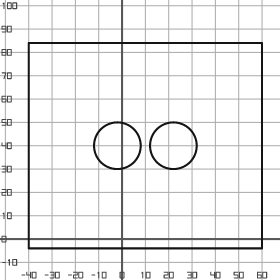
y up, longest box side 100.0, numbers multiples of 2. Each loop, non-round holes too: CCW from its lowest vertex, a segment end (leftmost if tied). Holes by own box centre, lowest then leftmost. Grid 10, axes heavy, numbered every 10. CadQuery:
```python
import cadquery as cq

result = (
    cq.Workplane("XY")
    .moveTo(-40.0, -4.0)
    .lineTo(60.0, -4.0)
    .lineTo(60.0, 84.0)
    .lineTo(-40.0, 84.0)
    .close()
    .moveTo(-2.0, 40.0)
    .circle(10.0)
    .moveTo(22.0, 40.0)
    .circle(10.0)
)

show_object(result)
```